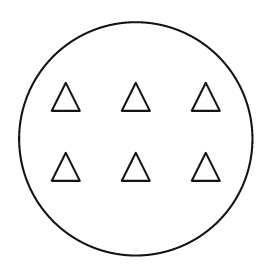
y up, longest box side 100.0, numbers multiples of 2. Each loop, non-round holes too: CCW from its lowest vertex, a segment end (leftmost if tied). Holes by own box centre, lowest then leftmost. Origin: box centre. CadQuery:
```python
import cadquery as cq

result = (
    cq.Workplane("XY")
    .moveTo(0.0, 0.0)
    .circle(50.0)
    .moveTo(-36.0, -18.0)
    .lineTo(-24.0, -18.0)
    .lineTo(-30.0, -6.0)
    .close()
    .moveTo(-6.0, -18.0)
    .lineTo(6.0, -18.0)
    .lineTo(0.0, -6.0)
    .close()
    .moveTo(24.0, -18.0)
    .lineTo(36.0, -18.0)
    .lineTo(30.0, -6.0)
    .close()
    .moveTo(-36.0, 12.0)
    .lineTo(-24.0, 12.0)
    .lineTo(-30.0, 24.0)
    .close()
    .moveTo(-6.0, 12.0)
    .lineTo(6.0, 12.0)
    .lineTo(0.0, 24.0)
    .close()
    .moveTo(24.0, 12.0)
    .lineTo(36.0, 12.0)
    .lineTo(30.0, 24.0)
    .close()
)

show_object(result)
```